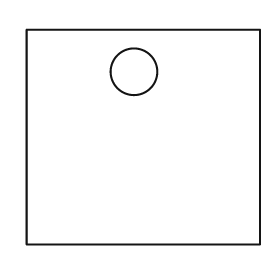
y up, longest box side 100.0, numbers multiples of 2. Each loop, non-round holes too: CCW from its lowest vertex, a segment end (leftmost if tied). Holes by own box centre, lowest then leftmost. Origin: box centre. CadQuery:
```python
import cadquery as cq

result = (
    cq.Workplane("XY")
    .moveTo(-50.0, -46.0)
    .lineTo(50.0, -46.0)
    .lineTo(50.0, 46.0)
    .lineTo(-50.0, 46.0)
    .close()
    .moveTo(-4.0, 28.0)
    .circle(10.0)
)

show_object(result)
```